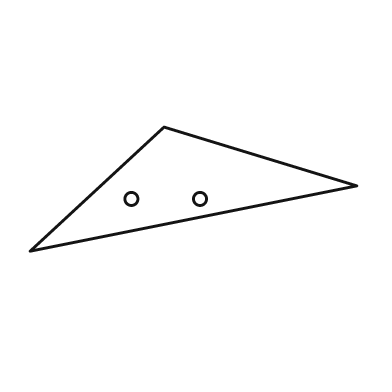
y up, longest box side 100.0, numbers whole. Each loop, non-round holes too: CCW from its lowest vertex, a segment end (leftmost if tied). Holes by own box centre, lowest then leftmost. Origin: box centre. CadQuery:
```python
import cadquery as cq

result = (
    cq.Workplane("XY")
    .moveTo(-50.0, -19.0)
    .lineTo(50.0, 1.0)
    .lineTo(-9.0, 19.0)
    .close()
    .moveTo(-19.0, -3.0)
    .circle(2.0)
    .moveTo(2.0, -3.0)
    .circle(2.0)
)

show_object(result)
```